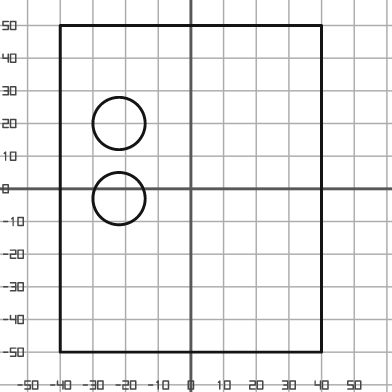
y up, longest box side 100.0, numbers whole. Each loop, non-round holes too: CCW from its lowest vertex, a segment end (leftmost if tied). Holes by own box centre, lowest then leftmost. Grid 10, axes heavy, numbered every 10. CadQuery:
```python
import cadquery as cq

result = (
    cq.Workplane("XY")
    .moveTo(-40.0, -50.0)
    .lineTo(40.0, -50.0)
    .lineTo(40.0, 50.0)
    .lineTo(-40.0, 50.0)
    .close()
    .moveTo(-22.0, -3.0)
    .circle(8.0)
    .moveTo(-22.0, 20.0)
    .circle(8.0)
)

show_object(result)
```